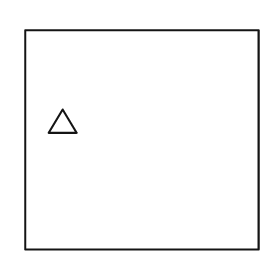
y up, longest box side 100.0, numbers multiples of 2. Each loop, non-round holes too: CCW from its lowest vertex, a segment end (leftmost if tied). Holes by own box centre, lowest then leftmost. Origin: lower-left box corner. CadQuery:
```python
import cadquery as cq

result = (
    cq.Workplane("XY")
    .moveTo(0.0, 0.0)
    .lineTo(100.0, 0.0)
    .lineTo(100.0, 94.0)
    .lineTo(0.0, 94.0)
    .close()
    .moveTo(10.0, 50.0)
    .lineTo(22.0, 50.0)
    .lineTo(16.0, 60.0)
    .close()
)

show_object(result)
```